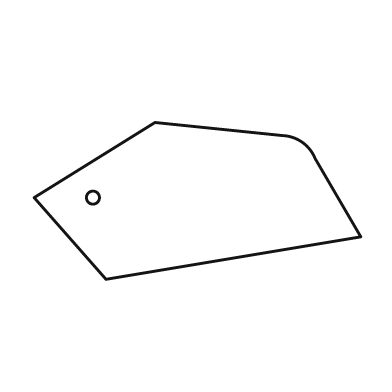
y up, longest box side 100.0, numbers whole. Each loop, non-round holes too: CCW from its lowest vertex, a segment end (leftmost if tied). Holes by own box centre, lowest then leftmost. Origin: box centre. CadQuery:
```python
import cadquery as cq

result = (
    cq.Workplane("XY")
    .moveTo(-28.0, -24.0)
    .lineTo(50.0, -11.0)
    .lineTo(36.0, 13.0)
    .threePointArc((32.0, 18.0), (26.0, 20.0))
    .lineTo(-13.0, 24.0)
    .lineTo(-50.0, 1.0)
    .close()
    .moveTo(-32.0, 1.0)
    .circle(2.0)
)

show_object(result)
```